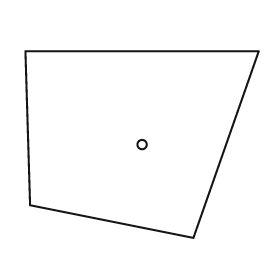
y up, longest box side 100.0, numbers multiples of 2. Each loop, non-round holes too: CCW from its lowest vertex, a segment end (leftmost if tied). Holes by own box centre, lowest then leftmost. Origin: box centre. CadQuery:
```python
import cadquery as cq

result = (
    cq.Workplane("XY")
    .moveTo(22.0, -40.0)
    .lineTo(50.0, 40.0)
    .lineTo(-50.0, 40.0)
    .lineTo(-48.0, -26.0)
    .close()
    .moveTo(0.0, 0.0)
    .circle(2.0)
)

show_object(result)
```